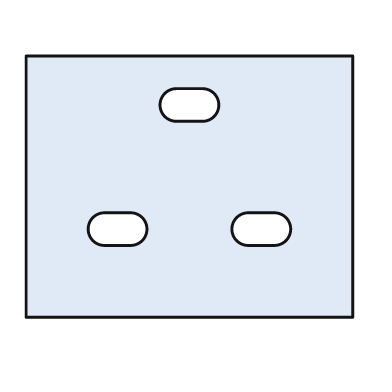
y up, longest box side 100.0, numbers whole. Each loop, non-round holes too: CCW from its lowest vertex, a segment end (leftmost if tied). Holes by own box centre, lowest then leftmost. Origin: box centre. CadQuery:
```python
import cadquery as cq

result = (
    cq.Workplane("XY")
    .moveTo(-50.0, -40.0)
    .lineTo(50.0, -40.0)
    .lineTo(50.0, 40.0)
    .lineTo(-50.0, 40.0)
    .close()
    .moveTo(-26.0, -18.0)
    .lineTo(-18.0, -18.0)
    .threePointArc((-13.0, -13.0), (-18.0, -8.0))
    .lineTo(-26.0, -8.0)
    .threePointArc((-31.0, -13.0), (-26.0, -18.0))
    .close()
    .moveTo(18.0, -18.0)
    .lineTo(26.0, -18.0)
    .threePointArc((31.0, -13.0), (26.0, -8.0))
    .lineTo(18.0, -8.0)
    .threePointArc((13.0, -13.0), (18.0, -18.0))
    .close()
    .moveTo(-4.0, 20.0)
    .lineTo(4.0, 20.0)
    .threePointArc((9.0, 25.0), (4.0, 30.0))
    .lineTo(-4.0, 30.0)
    .threePointArc((-9.0, 25.0), (-4.0, 20.0))
    .close()
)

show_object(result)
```